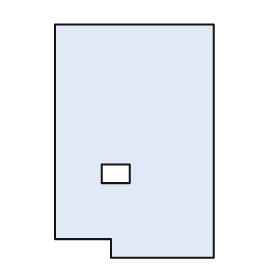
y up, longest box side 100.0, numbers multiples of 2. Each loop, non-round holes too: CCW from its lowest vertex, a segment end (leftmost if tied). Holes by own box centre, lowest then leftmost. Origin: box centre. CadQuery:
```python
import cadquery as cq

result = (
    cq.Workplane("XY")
    .moveTo(-10.0, -50.0)
    .lineTo(34.0, -50.0)
    .lineTo(34.0, 50.0)
    .lineTo(-34.0, 50.0)
    .lineTo(-34.0, -42.0)
    .lineTo(-10.0, -42.0)
    .close()
    .moveTo(-14.0, -18.0)
    .lineTo(-2.0, -18.0)
    .lineTo(-2.0, -10.0)
    .lineTo(-14.0, -10.0)
    .close()
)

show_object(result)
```